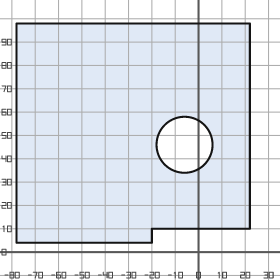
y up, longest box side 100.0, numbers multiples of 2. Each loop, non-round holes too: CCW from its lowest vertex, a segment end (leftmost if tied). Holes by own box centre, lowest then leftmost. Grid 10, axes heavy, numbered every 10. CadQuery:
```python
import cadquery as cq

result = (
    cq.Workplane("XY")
    .moveTo(-78.0, 4.0)
    .lineTo(-20.0, 4.0)
    .lineTo(-20.0, 10.0)
    .lineTo(22.0, 10.0)
    .lineTo(22.0, 98.0)
    .lineTo(-78.0, 98.0)
    .close()
    .moveTo(-6.0, 46.0)
    .circle(12.0)
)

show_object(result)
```